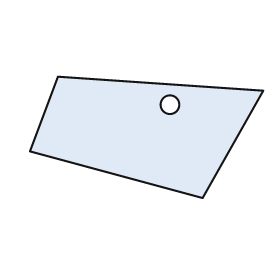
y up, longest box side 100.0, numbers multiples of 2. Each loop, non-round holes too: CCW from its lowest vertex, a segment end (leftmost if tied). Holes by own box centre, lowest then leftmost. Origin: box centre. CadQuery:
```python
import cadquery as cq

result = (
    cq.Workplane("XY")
    .moveTo(24.0, -26.0)
    .lineTo(50.0, 20.0)
    .lineTo(-38.0, 26.0)
    .lineTo(-50.0, -6.0)
    .close()
    .moveTo(10.0, 14.0)
    .circle(4.0)
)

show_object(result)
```